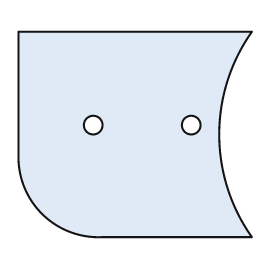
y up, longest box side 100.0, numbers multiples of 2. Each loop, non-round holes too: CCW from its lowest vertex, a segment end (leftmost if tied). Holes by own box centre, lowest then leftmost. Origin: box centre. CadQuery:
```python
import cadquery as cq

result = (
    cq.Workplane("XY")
    .moveTo(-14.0, -44.0)
    .lineTo(50.0, -44.0)
    .threePointArc((36.0, 0.0), (50.0, 44.0))
    .lineTo(-50.0, 44.0)
    .lineTo(-50.0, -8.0)
    .threePointArc((-40.0, -34.0), (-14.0, -44.0))
    .close()
    .moveTo(-18.0, 4.0)
    .circle(4.0)
    .moveTo(24.0, 4.0)
    .circle(4.0)
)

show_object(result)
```